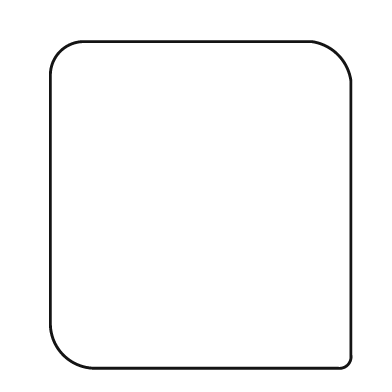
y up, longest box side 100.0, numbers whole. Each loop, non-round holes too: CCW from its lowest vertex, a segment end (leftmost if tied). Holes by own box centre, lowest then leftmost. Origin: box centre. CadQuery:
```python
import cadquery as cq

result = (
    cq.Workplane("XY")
    .moveTo(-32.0, -50.0)
    .lineTo(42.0, -50.0)
    .threePointArc((45.0, -49.0), (46.0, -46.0))
    .lineTo(46.0, 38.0)
    .threePointArc((42.0, 46.0), (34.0, 50.0))
    .lineTo(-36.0, 50.0)
    .threePointArc((-43.0, 47.0), (-46.0, 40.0))
    .lineTo(-46.0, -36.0)
    .threePointArc((-42.0, -46.0), (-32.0, -50.0))
    .close()
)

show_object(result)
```